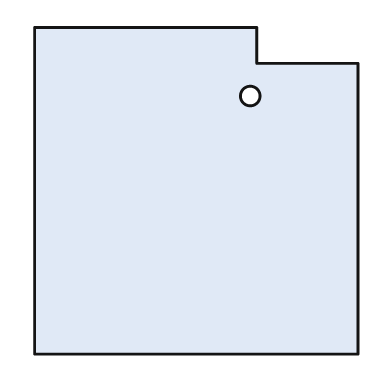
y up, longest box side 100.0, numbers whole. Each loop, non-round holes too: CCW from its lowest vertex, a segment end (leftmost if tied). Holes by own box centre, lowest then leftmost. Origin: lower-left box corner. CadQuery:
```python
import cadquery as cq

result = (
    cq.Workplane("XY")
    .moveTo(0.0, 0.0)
    .lineTo(99.0, 0.0)
    .lineTo(99.0, 89.0)
    .lineTo(68.0, 89.0)
    .lineTo(68.0, 100.0)
    .lineTo(0.0, 100.0)
    .close()
    .moveTo(66.0, 79.0)
    .circle(3.0)
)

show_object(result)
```